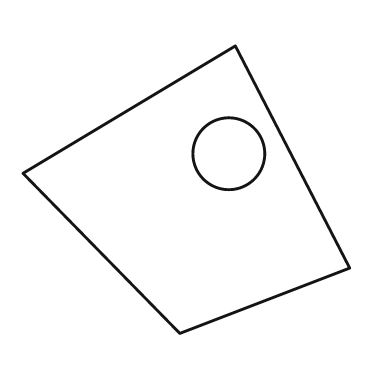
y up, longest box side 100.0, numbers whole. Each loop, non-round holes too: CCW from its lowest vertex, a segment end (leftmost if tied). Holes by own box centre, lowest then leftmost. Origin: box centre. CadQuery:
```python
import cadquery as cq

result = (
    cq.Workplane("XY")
    .moveTo(-2.0, -44.0)
    .lineTo(50.0, -24.0)
    .lineTo(15.0, 44.0)
    .lineTo(-50.0, 5.0)
    .close()
    .moveTo(13.0, 11.0)
    .circle(11.0)
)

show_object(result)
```